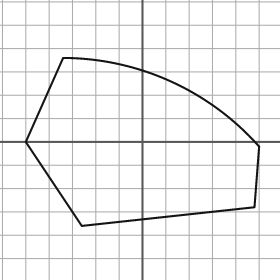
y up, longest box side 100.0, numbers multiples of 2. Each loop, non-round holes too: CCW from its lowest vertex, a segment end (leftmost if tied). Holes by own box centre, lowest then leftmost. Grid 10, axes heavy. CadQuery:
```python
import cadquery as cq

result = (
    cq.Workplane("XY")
    .moveTo(-26.0, -36.0)
    .lineTo(48.0, -28.0)
    .lineTo(50.0, -2.0)
    .threePointArc((12.0, 26.0), (-34.0, 36.0))
    .lineTo(-50.0, 0.0)
    .close()
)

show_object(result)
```